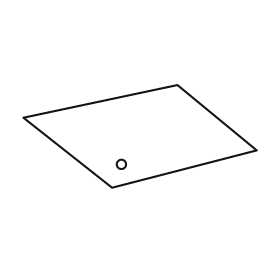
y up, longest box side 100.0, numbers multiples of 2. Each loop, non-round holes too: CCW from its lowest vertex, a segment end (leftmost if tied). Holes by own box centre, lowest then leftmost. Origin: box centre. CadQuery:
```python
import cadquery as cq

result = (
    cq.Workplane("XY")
    .moveTo(-12.0, -22.0)
    .lineTo(50.0, -6.0)
    .lineTo(16.0, 22.0)
    .lineTo(-50.0, 8.0)
    .close()
    .moveTo(-8.0, -12.0)
    .circle(2.0)
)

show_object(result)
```